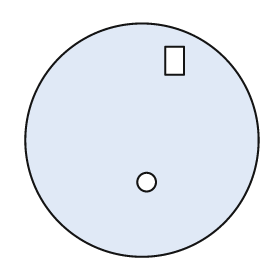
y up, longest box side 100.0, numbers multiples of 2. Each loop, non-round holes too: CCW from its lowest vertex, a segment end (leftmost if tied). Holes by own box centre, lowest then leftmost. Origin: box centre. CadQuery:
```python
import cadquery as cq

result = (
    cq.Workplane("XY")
    .moveTo(0.0, 0.0)
    .circle(50.0)
    .moveTo(2.0, -18.0)
    .circle(4.0)
    .moveTo(10.0, 28.0)
    .lineTo(18.0, 28.0)
    .lineTo(18.0, 40.0)
    .lineTo(10.0, 40.0)
    .close()
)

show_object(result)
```